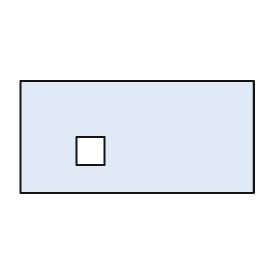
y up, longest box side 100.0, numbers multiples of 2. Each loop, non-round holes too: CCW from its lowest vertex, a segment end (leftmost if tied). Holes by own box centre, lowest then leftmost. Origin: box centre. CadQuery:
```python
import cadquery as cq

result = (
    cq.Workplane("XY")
    .moveTo(-50.0, -24.0)
    .lineTo(50.0, -24.0)
    .lineTo(50.0, 24.0)
    .lineTo(-50.0, 24.0)
    .close()
    .moveTo(-26.0, -12.0)
    .lineTo(-14.0, -12.0)
    .lineTo(-14.0, 0.0)
    .lineTo(-26.0, 0.0)
    .close()
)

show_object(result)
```